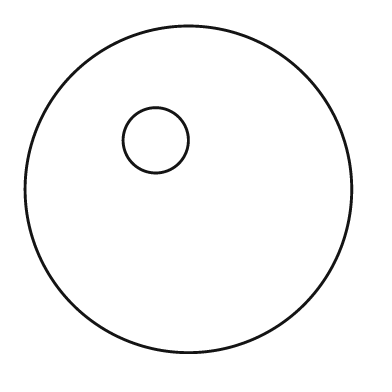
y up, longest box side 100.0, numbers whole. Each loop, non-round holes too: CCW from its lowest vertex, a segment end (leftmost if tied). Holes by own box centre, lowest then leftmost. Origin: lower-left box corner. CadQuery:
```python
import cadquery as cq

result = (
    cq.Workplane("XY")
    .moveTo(50.0, 50.0)
    .circle(50.0)
    .moveTo(40.0, 65.0)
    .circle(10.0)
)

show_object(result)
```